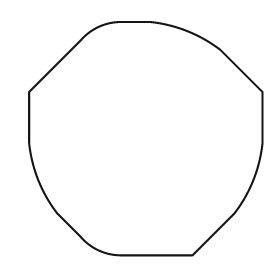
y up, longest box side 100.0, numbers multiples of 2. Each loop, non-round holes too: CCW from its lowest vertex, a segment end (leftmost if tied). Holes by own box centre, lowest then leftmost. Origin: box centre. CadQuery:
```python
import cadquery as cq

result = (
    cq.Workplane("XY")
    .moveTo(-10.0, -50.0)
    .lineTo(20.0, -50.0)
    .lineTo(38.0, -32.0)
    .threePointArc((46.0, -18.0), (50.0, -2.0))
    .lineTo(50.0, 20.0)
    .lineTo(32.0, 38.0)
    .threePointArc((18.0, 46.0), (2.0, 50.0))
    .lineTo(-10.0, 50.0)
    .threePointArc((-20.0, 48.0), (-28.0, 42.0))
    .lineTo(-50.0, 20.0)
    .lineTo(-50.0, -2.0)
    .threePointArc((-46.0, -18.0), (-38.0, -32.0))
    .lineTo(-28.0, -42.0)
    .threePointArc((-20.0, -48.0), (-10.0, -50.0))
    .close()
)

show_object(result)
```